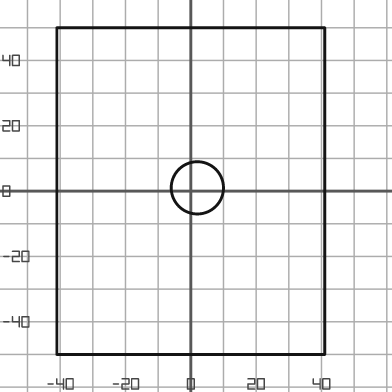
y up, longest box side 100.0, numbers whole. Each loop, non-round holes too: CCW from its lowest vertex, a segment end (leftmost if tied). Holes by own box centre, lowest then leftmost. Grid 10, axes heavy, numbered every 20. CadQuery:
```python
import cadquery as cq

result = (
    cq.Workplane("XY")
    .moveTo(-41.0, -50.0)
    .lineTo(41.0, -50.0)
    .lineTo(41.0, 50.0)
    .lineTo(-41.0, 50.0)
    .close()
    .moveTo(2.0, 1.0)
    .circle(8.0)
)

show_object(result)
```